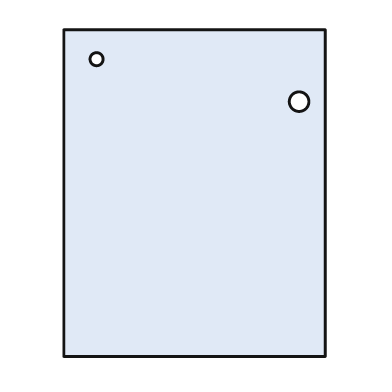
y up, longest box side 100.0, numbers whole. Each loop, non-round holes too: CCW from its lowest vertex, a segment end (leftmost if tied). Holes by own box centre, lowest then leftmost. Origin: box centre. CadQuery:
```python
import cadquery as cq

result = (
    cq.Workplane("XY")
    .moveTo(-40.0, -50.0)
    .lineTo(40.0, -50.0)
    .lineTo(40.0, 50.0)
    .lineTo(-40.0, 50.0)
    .close()
    .moveTo(32.0, 28.0)
    .circle(3.0)
    .moveTo(-30.0, 41.0)
    .circle(2.0)
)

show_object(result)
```